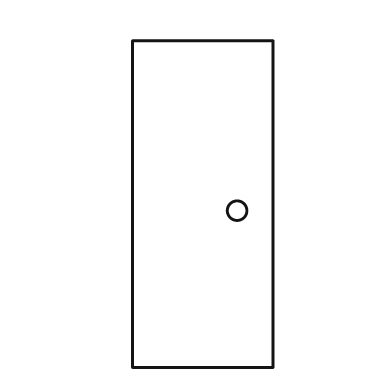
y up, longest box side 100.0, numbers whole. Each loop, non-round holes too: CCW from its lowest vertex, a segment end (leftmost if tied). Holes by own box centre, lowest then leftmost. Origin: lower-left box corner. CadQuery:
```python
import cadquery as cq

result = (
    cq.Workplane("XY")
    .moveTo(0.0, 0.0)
    .lineTo(43.0, 0.0)
    .lineTo(43.0, 100.0)
    .lineTo(0.0, 100.0)
    .close()
    .moveTo(32.0, 48.0)
    .circle(3.0)
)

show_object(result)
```